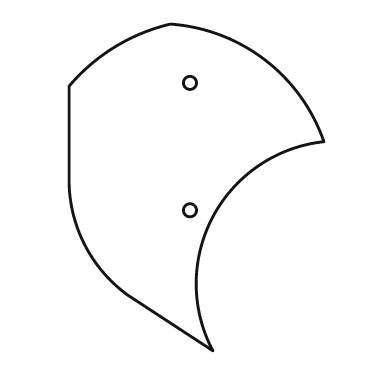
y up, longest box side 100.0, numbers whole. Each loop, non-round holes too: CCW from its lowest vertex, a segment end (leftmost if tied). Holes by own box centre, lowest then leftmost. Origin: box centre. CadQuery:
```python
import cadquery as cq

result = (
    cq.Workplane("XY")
    .moveTo(5.0, -50.0)
    .threePointArc((5.0, -9.0), (39.0, 14.0))
    .threePointArc((21.0, 39.0), (-8.0, 50.0))
    .threePointArc((-25.0, 43.0), (-39.0, 31.0))
    .lineTo(-39.0, 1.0)
    .threePointArc((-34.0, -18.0), (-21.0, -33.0))
    .close()
    .moveTo(-2.0, -7.0)
    .circle(2.0)
    .moveTo(-2.0, 32.0)
    .circle(2.0)
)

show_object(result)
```